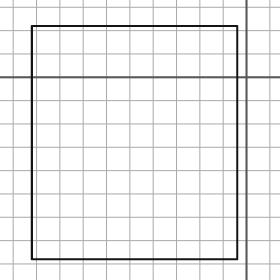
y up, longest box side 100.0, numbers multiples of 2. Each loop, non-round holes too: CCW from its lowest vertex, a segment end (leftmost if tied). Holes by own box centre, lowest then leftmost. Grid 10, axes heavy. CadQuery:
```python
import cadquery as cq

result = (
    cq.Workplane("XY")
    .moveTo(-92.0, -78.0)
    .lineTo(-4.0, -78.0)
    .lineTo(-4.0, 22.0)
    .lineTo(-92.0, 22.0)
    .close()
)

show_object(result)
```